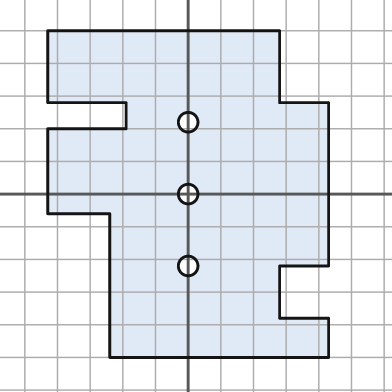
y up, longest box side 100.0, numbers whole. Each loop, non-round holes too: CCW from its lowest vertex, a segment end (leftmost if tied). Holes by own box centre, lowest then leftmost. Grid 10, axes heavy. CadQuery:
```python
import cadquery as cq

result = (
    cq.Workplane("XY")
    .moveTo(-24.0, -50.0)
    .lineTo(43.0, -50.0)
    .lineTo(43.0, -38.0)
    .lineTo(28.0, -38.0)
    .lineTo(28.0, -22.0)
    .lineTo(43.0, -22.0)
    .lineTo(43.0, 28.0)
    .lineTo(28.0, 28.0)
    .lineTo(28.0, 50.0)
    .lineTo(-43.0, 50.0)
    .lineTo(-43.0, 28.0)
    .lineTo(-19.0, 28.0)
    .lineTo(-19.0, 20.0)
    .lineTo(-43.0, 20.0)
    .lineTo(-43.0, -6.0)
    .lineTo(-24.0, -6.0)
    .close()
    .moveTo(0.0, -22.0)
    .circle(3.0)
    .moveTo(0.0, 0.0)
    .circle(3.0)
    .moveTo(0.0, 22.0)
    .circle(3.0)
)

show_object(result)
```